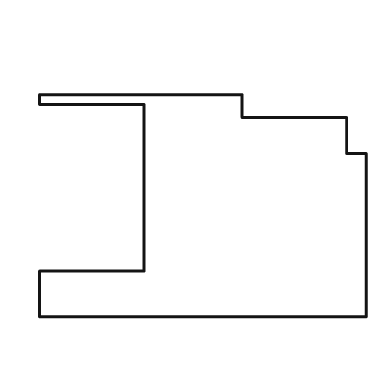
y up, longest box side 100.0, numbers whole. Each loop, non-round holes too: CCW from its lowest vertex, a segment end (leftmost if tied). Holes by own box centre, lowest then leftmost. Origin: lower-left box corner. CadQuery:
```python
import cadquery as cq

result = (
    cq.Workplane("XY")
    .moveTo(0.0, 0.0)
    .lineTo(100.0, 0.0)
    .lineTo(100.0, 50.0)
    .lineTo(94.0, 50.0)
    .lineTo(94.0, 61.0)
    .lineTo(62.0, 61.0)
    .lineTo(62.0, 68.0)
    .lineTo(0.0, 68.0)
    .lineTo(0.0, 65.0)
    .lineTo(32.0, 65.0)
    .lineTo(32.0, 14.0)
    .lineTo(0.0, 14.0)
    .close()
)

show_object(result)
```